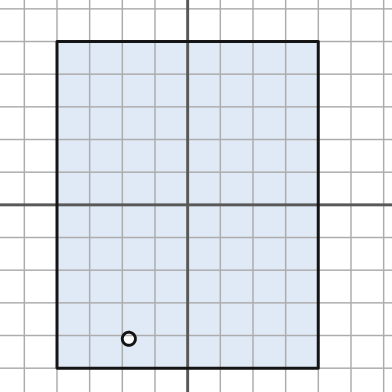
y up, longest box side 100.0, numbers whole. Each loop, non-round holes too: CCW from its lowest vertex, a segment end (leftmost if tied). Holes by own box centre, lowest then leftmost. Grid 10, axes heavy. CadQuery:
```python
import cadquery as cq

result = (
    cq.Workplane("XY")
    .moveTo(-40.0, -50.0)
    .lineTo(40.0, -50.0)
    .lineTo(40.0, 50.0)
    .lineTo(-40.0, 50.0)
    .close()
    .moveTo(-18.0, -41.0)
    .circle(2.0)
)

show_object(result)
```